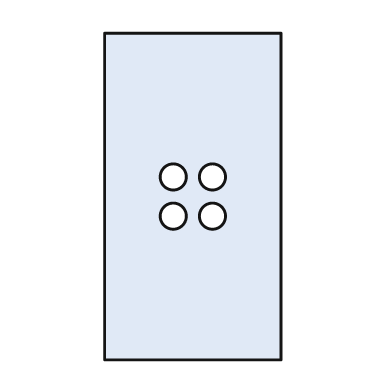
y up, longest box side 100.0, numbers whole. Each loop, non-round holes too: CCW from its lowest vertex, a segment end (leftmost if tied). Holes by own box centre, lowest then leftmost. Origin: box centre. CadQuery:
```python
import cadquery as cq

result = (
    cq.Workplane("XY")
    .moveTo(-27.0, -50.0)
    .lineTo(27.0, -50.0)
    .lineTo(27.0, 50.0)
    .lineTo(-27.0, 50.0)
    .close()
    .moveTo(-6.0, -6.0)
    .circle(4.0)
    .moveTo(6.0, -6.0)
    .circle(4.0)
    .moveTo(-6.0, 6.0)
    .circle(4.0)
    .moveTo(6.0, 6.0)
    .circle(4.0)
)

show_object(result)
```